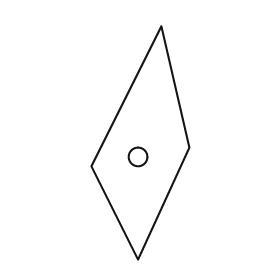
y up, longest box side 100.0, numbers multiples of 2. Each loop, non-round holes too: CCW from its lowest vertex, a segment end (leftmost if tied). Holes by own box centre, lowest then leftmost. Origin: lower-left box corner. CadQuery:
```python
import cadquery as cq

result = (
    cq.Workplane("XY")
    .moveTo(20.0, 0.0)
    .lineTo(42.0, 48.0)
    .lineTo(30.0, 100.0)
    .lineTo(0.0, 40.0)
    .close()
    .moveTo(20.0, 44.0)
    .circle(4.0)
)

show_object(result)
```